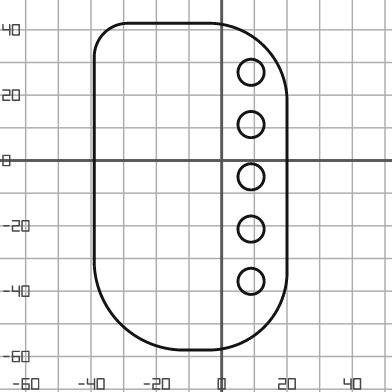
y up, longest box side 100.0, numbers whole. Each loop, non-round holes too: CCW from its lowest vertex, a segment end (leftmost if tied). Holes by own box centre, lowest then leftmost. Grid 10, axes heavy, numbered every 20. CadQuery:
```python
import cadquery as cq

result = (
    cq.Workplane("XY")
    .moveTo(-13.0, -58.0)
    .lineTo(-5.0, -58.0)
    .threePointArc((13.0, -51.0), (20.0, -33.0))
    .lineTo(20.0, 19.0)
    .threePointArc((13.0, 35.0), (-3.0, 42.0))
    .lineTo(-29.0, 42.0)
    .threePointArc((-36.0, 39.0), (-39.0, 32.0))
    .lineTo(-39.0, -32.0)
    .threePointArc((-31.0, -50.0), (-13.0, -58.0))
    .close()
    .moveTo(9.0, -37.0)
    .circle(4.0)
    .moveTo(9.0, -21.0)
    .circle(4.0)
    .moveTo(9.0, -5.0)
    .circle(4.0)
    .moveTo(9.0, 11.0)
    .circle(4.0)
    .moveTo(9.0, 27.0)
    .circle(4.0)
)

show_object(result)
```